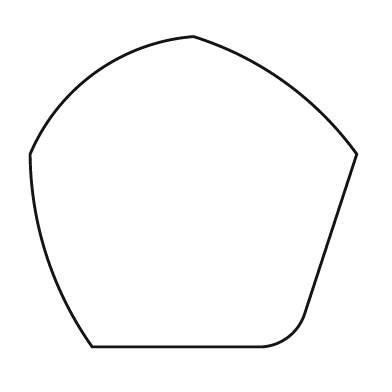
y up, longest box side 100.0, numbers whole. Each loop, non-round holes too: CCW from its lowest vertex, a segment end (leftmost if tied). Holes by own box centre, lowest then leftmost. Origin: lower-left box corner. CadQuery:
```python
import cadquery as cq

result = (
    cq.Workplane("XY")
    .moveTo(19.0, 0.0)
    .lineTo(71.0, 0.0)
    .threePointArc((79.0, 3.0), (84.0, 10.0))
    .lineTo(100.0, 59.0)
    .threePointArc((78.0, 81.0), (50.0, 95.0))
    .threePointArc((20.0, 84.0), (0.0, 59.0))
    .threePointArc((5.0, 28.0), (19.0, 0.0))
    .close()
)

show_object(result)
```